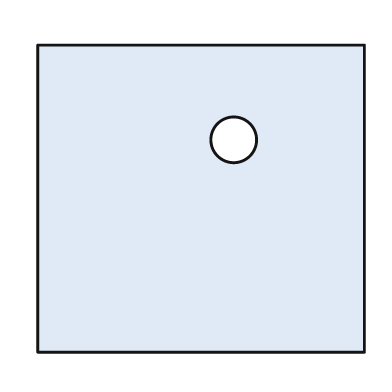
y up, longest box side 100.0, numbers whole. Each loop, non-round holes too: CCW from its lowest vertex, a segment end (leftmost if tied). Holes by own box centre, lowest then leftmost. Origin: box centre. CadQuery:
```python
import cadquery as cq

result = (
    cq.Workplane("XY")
    .moveTo(-50.0, -47.0)
    .lineTo(50.0, -47.0)
    .lineTo(50.0, 47.0)
    .lineTo(-50.0, 47.0)
    .close()
    .moveTo(10.0, 18.0)
    .circle(7.0)
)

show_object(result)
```